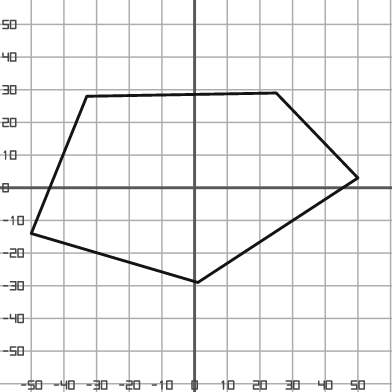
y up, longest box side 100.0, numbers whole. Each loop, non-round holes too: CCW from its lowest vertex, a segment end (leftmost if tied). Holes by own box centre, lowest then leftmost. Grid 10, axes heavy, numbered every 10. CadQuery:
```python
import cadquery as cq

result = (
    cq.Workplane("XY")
    .moveTo(1.0, -29.0)
    .lineTo(50.0, 3.0)
    .lineTo(25.0, 29.0)
    .lineTo(-33.0, 28.0)
    .lineTo(-50.0, -14.0)
    .close()
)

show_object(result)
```